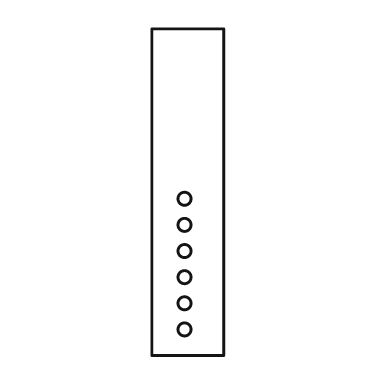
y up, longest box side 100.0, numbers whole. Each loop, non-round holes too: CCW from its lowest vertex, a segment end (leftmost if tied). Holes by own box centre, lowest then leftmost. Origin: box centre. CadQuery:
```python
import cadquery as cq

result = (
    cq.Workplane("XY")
    .moveTo(-11.0, -50.0)
    .lineTo(11.0, -50.0)
    .lineTo(11.0, 50.0)
    .lineTo(-11.0, 50.0)
    .close()
    .moveTo(-1.0, -42.0)
    .circle(2.0)
    .moveTo(-1.0, -34.0)
    .circle(2.0)
    .moveTo(-1.0, -26.0)
    .circle(2.0)
    .moveTo(-1.0, -18.0)
    .circle(2.0)
    .moveTo(-1.0, -10.0)
    .circle(2.0)
    .moveTo(-1.0, -2.0)
    .circle(2.0)
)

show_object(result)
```